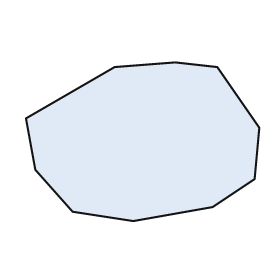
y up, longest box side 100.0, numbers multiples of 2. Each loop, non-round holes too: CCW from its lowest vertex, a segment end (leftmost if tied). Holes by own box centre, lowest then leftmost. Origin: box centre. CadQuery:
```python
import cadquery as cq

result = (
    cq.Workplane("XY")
    .moveTo(-4.0, -34.0)
    .lineTo(30.0, -28.0)
    .lineTo(48.0, -16.0)
    .lineTo(50.0, 6.0)
    .lineTo(32.0, 32.0)
    .lineTo(14.0, 34.0)
    .lineTo(-12.0, 32.0)
    .lineTo(-50.0, 10.0)
    .lineTo(-46.0, -12.0)
    .lineTo(-30.0, -30.0)
    .close()
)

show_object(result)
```